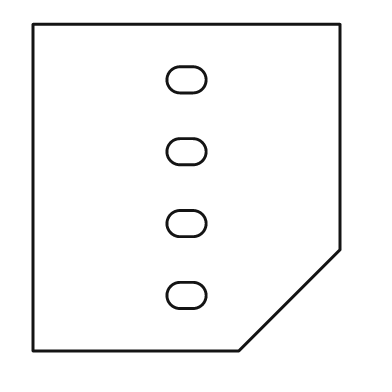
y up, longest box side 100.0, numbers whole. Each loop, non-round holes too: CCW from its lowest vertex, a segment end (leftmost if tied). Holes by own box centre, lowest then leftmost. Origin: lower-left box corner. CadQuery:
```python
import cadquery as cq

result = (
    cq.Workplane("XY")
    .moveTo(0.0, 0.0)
    .lineTo(63.0, 0.0)
    .lineTo(94.0, 31.0)
    .lineTo(94.0, 100.0)
    .lineTo(0.0, 100.0)
    .close()
    .moveTo(45.0, 13.0)
    .lineTo(49.0, 13.0)
    .threePointArc((53.0, 17.0), (49.0, 21.0))
    .lineTo(45.0, 21.0)
    .threePointArc((41.0, 17.0), (45.0, 13.0))
    .close()
    .moveTo(45.0, 35.0)
    .lineTo(49.0, 35.0)
    .threePointArc((53.0, 39.0), (49.0, 43.0))
    .lineTo(45.0, 43.0)
    .threePointArc((41.0, 39.0), (45.0, 35.0))
    .close()
    .moveTo(45.0, 57.0)
    .lineTo(49.0, 57.0)
    .threePointArc((53.0, 61.0), (49.0, 65.0))
    .lineTo(45.0, 65.0)
    .threePointArc((41.0, 61.0), (45.0, 57.0))
    .close()
    .moveTo(45.0, 79.0)
    .lineTo(49.0, 79.0)
    .threePointArc((53.0, 83.0), (49.0, 87.0))
    .lineTo(45.0, 87.0)
    .threePointArc((41.0, 83.0), (45.0, 79.0))
    .close()
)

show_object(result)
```